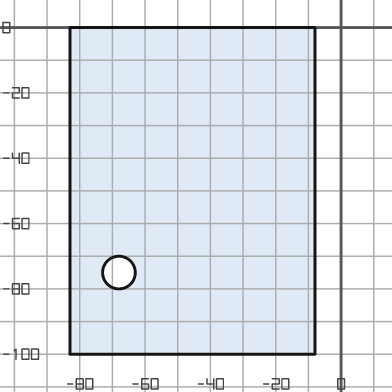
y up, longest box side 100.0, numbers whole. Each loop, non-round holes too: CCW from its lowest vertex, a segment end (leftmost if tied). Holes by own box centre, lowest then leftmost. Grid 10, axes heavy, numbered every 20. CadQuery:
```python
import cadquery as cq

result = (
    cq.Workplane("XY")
    .moveTo(-83.0, -100.0)
    .lineTo(-8.0, -100.0)
    .lineTo(-8.0, 0.0)
    .lineTo(-83.0, 0.0)
    .close()
    .moveTo(-68.0, -75.0)
    .circle(5.0)
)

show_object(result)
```